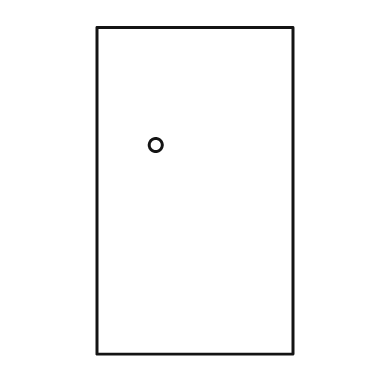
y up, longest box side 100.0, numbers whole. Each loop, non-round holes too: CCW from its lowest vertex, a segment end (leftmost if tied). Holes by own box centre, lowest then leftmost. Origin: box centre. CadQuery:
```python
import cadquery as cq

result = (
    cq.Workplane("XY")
    .moveTo(-30.0, -50.0)
    .lineTo(30.0, -50.0)
    .lineTo(30.0, 50.0)
    .lineTo(-30.0, 50.0)
    .close()
    .moveTo(-12.0, 14.0)
    .circle(2.0)
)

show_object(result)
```